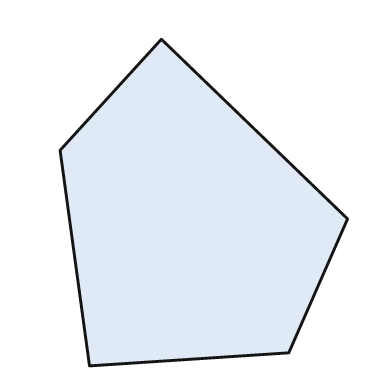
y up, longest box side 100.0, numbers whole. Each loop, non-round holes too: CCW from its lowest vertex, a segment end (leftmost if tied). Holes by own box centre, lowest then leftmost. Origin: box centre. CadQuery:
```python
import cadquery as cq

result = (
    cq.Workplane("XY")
    .moveTo(-35.0, -50.0)
    .lineTo(26.0, -46.0)
    .lineTo(44.0, -5.0)
    .lineTo(-13.0, 50.0)
    .lineTo(-44.0, 16.0)
    .close()
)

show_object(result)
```